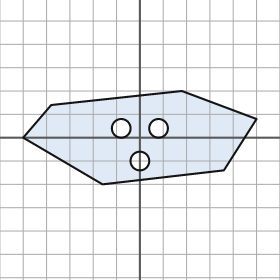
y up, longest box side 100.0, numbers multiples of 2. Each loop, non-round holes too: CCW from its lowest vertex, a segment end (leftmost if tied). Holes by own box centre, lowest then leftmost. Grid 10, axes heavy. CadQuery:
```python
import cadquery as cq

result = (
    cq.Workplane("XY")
    .moveTo(-16.0, -20.0)
    .lineTo(36.0, -14.0)
    .lineTo(50.0, 8.0)
    .lineTo(18.0, 20.0)
    .lineTo(-38.0, 14.0)
    .lineTo(-50.0, 0.0)
    .close()
    .moveTo(0.0, -10.0)
    .circle(4.0)
    .moveTo(-8.0, 4.0)
    .circle(4.0)
    .moveTo(8.0, 4.0)
    .circle(4.0)
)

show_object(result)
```